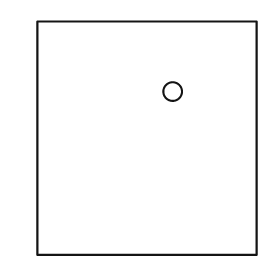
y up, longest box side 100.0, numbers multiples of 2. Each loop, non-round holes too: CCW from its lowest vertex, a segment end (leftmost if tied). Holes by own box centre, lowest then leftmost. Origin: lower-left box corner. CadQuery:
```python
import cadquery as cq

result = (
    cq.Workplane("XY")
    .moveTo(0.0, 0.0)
    .lineTo(94.0, 0.0)
    .lineTo(94.0, 100.0)
    .lineTo(0.0, 100.0)
    .close()
    .moveTo(58.0, 70.0)
    .circle(4.0)
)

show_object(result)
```